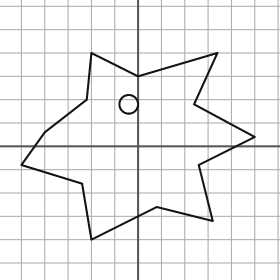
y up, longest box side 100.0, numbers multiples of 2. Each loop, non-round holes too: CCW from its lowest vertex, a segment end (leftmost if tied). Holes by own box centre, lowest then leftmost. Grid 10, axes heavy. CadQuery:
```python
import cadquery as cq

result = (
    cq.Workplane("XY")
    .moveTo(-20.0, -40.0)
    .lineTo(8.0, -26.0)
    .lineTo(32.0, -32.0)
    .lineTo(26.0, -8.0)
    .lineTo(50.0, 4.0)
    .lineTo(24.0, 18.0)
    .lineTo(34.0, 40.0)
    .lineTo(0.0, 30.0)
    .lineTo(-20.0, 40.0)
    .lineTo(-22.0, 20.0)
    .lineTo(-40.0, 6.0)
    .lineTo(-50.0, -8.0)
    .lineTo(-24.0, -16.0)
    .close()
    .moveTo(-4.0, 18.0)
    .circle(4.0)
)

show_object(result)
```